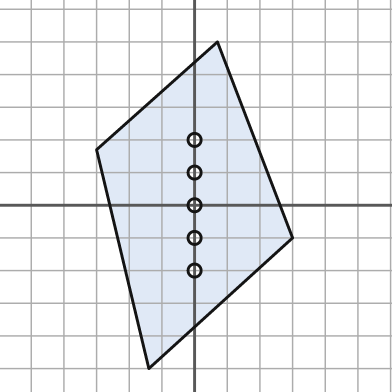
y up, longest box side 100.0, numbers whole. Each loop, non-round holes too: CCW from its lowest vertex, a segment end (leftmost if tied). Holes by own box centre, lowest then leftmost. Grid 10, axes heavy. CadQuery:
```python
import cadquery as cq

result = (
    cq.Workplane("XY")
    .moveTo(-14.0, -50.0)
    .lineTo(30.0, -10.0)
    .lineTo(7.0, 50.0)
    .lineTo(-30.0, 17.0)
    .close()
    .moveTo(0.0, -20.0)
    .circle(2.0)
    .moveTo(0.0, -10.0)
    .circle(2.0)
    .moveTo(0.0, 0.0)
    .circle(2.0)
    .moveTo(0.0, 10.0)
    .circle(2.0)
    .moveTo(0.0, 20.0)
    .circle(2.0)
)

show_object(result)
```